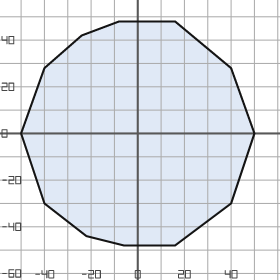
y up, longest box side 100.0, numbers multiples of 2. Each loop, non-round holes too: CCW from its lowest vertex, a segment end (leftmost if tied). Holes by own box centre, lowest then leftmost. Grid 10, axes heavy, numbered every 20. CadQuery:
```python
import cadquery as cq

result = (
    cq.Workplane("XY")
    .moveTo(-6.0, -48.0)
    .lineTo(16.0, -48.0)
    .lineTo(40.0, -30.0)
    .lineTo(50.0, 0.0)
    .lineTo(40.0, 28.0)
    .lineTo(16.0, 48.0)
    .lineTo(-8.0, 48.0)
    .lineTo(-24.0, 42.0)
    .lineTo(-40.0, 28.0)
    .lineTo(-50.0, 0.0)
    .lineTo(-40.0, -30.0)
    .lineTo(-22.0, -44.0)
    .close()
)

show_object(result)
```